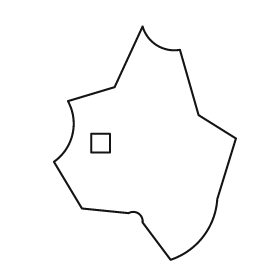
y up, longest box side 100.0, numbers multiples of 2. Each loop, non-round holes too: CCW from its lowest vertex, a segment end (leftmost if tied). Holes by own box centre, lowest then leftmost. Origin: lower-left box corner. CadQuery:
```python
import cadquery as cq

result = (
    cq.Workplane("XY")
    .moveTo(50.0, 0.0)
    .threePointArc((64.0, 10.0), (70.0, 26.0))
    .lineTo(78.0, 52.0)
    .lineTo(62.0, 62.0)
    .lineTo(54.0, 90.0)
    .threePointArc((44.0, 92.0), (38.0, 100.0))
    .lineTo(26.0, 74.0)
    .lineTo(6.0, 68.0)
    .threePointArc((8.0, 54.0), (0.0, 42.0))
    .lineTo(12.0, 22.0)
    .lineTo(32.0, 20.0)
    .threePointArc((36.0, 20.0), (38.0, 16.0))
    .close()
    .moveTo(16.0, 46.0)
    .lineTo(24.0, 46.0)
    .lineTo(24.0, 54.0)
    .lineTo(16.0, 54.0)
    .close()
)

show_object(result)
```